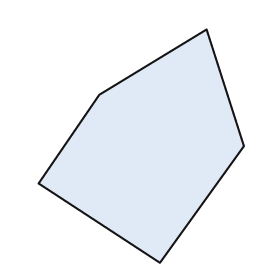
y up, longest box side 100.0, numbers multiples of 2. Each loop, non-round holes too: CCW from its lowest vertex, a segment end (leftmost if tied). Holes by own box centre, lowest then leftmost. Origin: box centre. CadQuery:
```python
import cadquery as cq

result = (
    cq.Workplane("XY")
    .moveTo(8.0, -50.0)
    .lineTo(44.0, 0.0)
    .lineTo(28.0, 50.0)
    .lineTo(-18.0, 22.0)
    .lineTo(-44.0, -16.0)
    .close()
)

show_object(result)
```